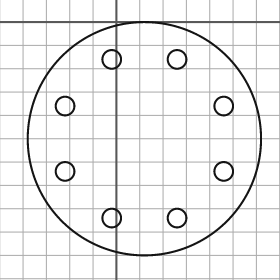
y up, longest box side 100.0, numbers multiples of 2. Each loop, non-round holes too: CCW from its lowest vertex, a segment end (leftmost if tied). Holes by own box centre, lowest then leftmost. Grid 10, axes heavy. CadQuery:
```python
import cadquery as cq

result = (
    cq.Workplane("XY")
    .moveTo(12.0, -50.0)
    .circle(50.0)
    .moveTo(-2.0, -84.0)
    .circle(4.0)
    .moveTo(26.0, -84.0)
    .circle(4.0)
    .moveTo(-22.0, -64.0)
    .circle(4.0)
    .moveTo(46.0, -64.0)
    .circle(4.0)
    .moveTo(-22.0, -36.0)
    .circle(4.0)
    .moveTo(46.0, -36.0)
    .circle(4.0)
    .moveTo(-2.0, -16.0)
    .circle(4.0)
    .moveTo(26.0, -16.0)
    .circle(4.0)
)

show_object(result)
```